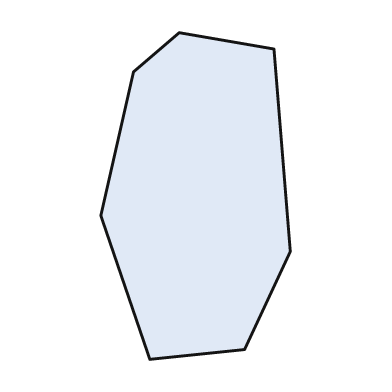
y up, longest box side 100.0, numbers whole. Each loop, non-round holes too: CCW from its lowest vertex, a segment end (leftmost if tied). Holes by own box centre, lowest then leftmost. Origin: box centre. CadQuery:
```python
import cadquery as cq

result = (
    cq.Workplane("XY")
    .moveTo(-14.0, -50.0)
    .lineTo(15.0, -47.0)
    .lineTo(29.0, -17.0)
    .lineTo(24.0, 45.0)
    .lineTo(-5.0, 50.0)
    .lineTo(-19.0, 38.0)
    .lineTo(-29.0, -6.0)
    .close()
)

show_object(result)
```